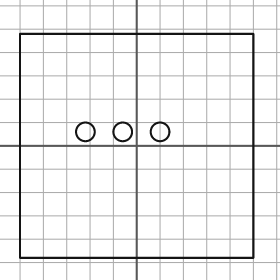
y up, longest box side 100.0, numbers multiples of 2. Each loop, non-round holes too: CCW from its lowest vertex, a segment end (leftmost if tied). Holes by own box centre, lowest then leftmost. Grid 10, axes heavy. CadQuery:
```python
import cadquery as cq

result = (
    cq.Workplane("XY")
    .moveTo(-50.0, -48.0)
    .lineTo(50.0, -48.0)
    .lineTo(50.0, 48.0)
    .lineTo(-50.0, 48.0)
    .close()
    .moveTo(-22.0, 6.0)
    .circle(4.0)
    .moveTo(-6.0, 6.0)
    .circle(4.0)
    .moveTo(10.0, 6.0)
    .circle(4.0)
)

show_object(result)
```